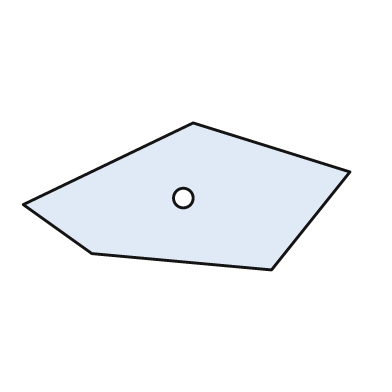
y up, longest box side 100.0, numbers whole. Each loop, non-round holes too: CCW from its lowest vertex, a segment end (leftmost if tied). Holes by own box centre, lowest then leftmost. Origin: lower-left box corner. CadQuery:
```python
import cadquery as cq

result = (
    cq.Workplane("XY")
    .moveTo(76.0, 0.0)
    .lineTo(100.0, 30.0)
    .lineTo(52.0, 45.0)
    .lineTo(0.0, 20.0)
    .lineTo(21.0, 5.0)
    .close()
    .moveTo(49.0, 22.0)
    .circle(3.0)
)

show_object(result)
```